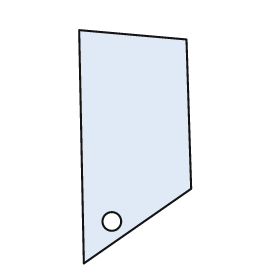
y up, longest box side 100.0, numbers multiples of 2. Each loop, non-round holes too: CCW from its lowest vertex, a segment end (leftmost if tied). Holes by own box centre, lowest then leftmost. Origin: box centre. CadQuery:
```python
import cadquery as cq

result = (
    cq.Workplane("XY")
    .moveTo(-22.0, -50.0)
    .lineTo(24.0, -18.0)
    .lineTo(22.0, 46.0)
    .lineTo(-24.0, 50.0)
    .close()
    .moveTo(-10.0, -32.0)
    .circle(4.0)
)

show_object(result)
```